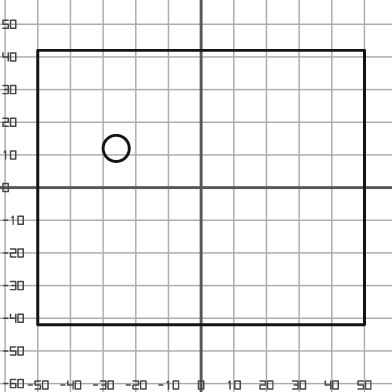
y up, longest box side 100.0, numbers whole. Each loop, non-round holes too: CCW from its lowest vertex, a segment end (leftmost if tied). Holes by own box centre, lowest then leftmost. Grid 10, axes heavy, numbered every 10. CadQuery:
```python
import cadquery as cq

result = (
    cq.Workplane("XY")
    .moveTo(-50.0, -42.0)
    .lineTo(50.0, -42.0)
    .lineTo(50.0, 42.0)
    .lineTo(-50.0, 42.0)
    .close()
    .moveTo(-26.0, 12.0)
    .circle(4.0)
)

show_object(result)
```